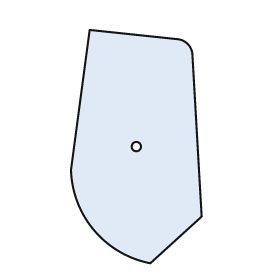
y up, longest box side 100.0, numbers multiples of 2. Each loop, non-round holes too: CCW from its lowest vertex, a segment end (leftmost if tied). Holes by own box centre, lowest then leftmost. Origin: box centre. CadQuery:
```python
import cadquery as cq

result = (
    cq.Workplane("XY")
    .moveTo(6.0, -50.0)
    .lineTo(28.0, -30.0)
    .lineTo(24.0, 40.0)
    .threePointArc((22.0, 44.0), (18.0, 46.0))
    .lineTo(-20.0, 50.0)
    .lineTo(-28.0, -10.0)
    .threePointArc((-18.0, -36.0), (6.0, -50.0))
    .close()
    .moveTo(0.0, 0.0)
    .circle(2.0)
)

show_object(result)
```